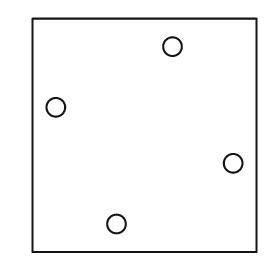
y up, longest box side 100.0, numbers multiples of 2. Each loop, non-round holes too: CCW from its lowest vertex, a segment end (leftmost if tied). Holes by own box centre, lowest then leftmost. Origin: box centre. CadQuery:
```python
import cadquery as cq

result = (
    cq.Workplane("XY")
    .moveTo(-48.0, -50.0)
    .lineTo(48.0, -50.0)
    .lineTo(48.0, 50.0)
    .lineTo(-48.0, 50.0)
    .close()
    .moveTo(-12.0, -38.0)
    .circle(4.0)
    .moveTo(38.0, -12.0)
    .circle(4.0)
    .moveTo(-38.0, 12.0)
    .circle(4.0)
    .moveTo(12.0, 38.0)
    .circle(4.0)
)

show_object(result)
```